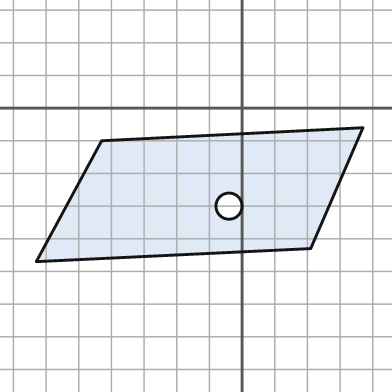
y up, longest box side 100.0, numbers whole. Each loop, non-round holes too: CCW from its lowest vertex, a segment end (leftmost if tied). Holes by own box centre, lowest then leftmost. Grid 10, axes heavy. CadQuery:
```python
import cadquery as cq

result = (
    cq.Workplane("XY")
    .moveTo(-63.0, -47.0)
    .lineTo(21.0, -43.0)
    .lineTo(37.0, -6.0)
    .lineTo(-43.0, -10.0)
    .close()
    .moveTo(-4.0, -30.0)
    .circle(4.0)
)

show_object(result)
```